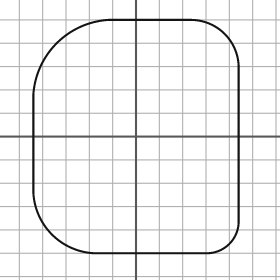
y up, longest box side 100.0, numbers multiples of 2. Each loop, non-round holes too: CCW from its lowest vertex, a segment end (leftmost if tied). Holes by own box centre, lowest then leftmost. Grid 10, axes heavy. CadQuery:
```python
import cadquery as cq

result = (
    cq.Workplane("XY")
    .moveTo(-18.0, -50.0)
    .lineTo(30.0, -50.0)
    .threePointArc((40.0, -46.0), (44.0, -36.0))
    .lineTo(44.0, 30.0)
    .threePointArc((38.0, 44.0), (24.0, 50.0))
    .lineTo(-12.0, 50.0)
    .threePointArc((-34.0, 40.0), (-44.0, 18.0))
    .lineTo(-44.0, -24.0)
    .threePointArc((-36.0, -42.0), (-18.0, -50.0))
    .close()
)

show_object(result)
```